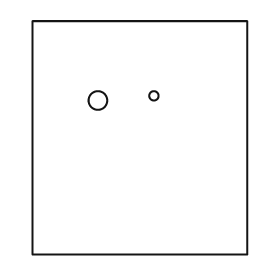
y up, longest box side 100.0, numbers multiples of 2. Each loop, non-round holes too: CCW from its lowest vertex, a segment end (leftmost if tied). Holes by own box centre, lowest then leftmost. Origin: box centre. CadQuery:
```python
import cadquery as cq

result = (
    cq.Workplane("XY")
    .moveTo(-46.0, -50.0)
    .lineTo(46.0, -50.0)
    .lineTo(46.0, 50.0)
    .lineTo(-46.0, 50.0)
    .close()
    .moveTo(-18.0, 16.0)
    .circle(4.0)
    .moveTo(6.0, 18.0)
    .circle(2.0)
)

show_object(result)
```